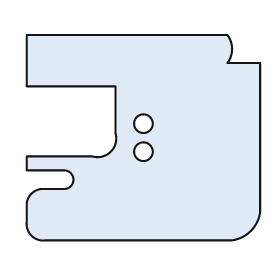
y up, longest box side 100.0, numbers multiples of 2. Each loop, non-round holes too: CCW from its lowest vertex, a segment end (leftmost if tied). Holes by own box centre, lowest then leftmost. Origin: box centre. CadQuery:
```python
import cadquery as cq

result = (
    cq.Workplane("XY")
    .moveTo(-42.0, -44.0)
    .lineTo(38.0, -44.0)
    .threePointArc((46.0, -40.0), (50.0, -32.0))
    .lineTo(50.0, 32.0)
    .lineTo(36.0, 32.0)
    .threePointArc((38.0, 38.0), (36.0, 44.0))
    .lineTo(-50.0, 44.0)
    .lineTo(-50.0, 22.0)
    .lineTo(-12.0, 22.0)
    .lineTo(-12.0, 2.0)
    .threePointArc((-14.0, -6.0), (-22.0, -8.0))
    .lineTo(-50.0, -8.0)
    .lineTo(-50.0, -14.0)
    .lineTo(-34.0, -14.0)
    .threePointArc((-30.0, -18.0), (-34.0, -22.0))
    .lineTo(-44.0, -22.0)
    .threePointArc((-48.0, -24.0), (-50.0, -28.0))
    .lineTo(-50.0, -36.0)
    .threePointArc((-48.0, -42.0), (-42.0, -44.0))
    .close()
    .moveTo(0.0, -6.0)
    .circle(4.0)
    .moveTo(0.0, 6.0)
    .circle(4.0)
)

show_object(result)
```